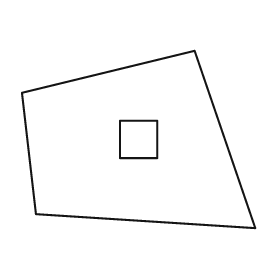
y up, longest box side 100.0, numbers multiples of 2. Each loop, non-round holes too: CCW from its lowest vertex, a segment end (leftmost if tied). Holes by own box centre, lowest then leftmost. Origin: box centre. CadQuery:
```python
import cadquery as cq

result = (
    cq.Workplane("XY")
    .moveTo(50.0, -38.0)
    .lineTo(24.0, 38.0)
    .lineTo(-50.0, 20.0)
    .lineTo(-44.0, -32.0)
    .close()
    .moveTo(-8.0, -8.0)
    .lineTo(8.0, -8.0)
    .lineTo(8.0, 8.0)
    .lineTo(-8.0, 8.0)
    .close()
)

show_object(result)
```